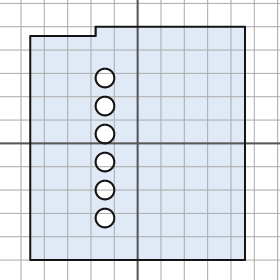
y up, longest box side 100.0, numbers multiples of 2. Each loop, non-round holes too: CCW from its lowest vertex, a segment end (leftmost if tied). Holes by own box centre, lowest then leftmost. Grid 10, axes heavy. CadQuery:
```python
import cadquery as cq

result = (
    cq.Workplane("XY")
    .moveTo(-46.0, -50.0)
    .lineTo(46.0, -50.0)
    .lineTo(46.0, 50.0)
    .lineTo(-18.0, 50.0)
    .lineTo(-18.0, 46.0)
    .lineTo(-46.0, 46.0)
    .close()
    .moveTo(-14.0, -32.0)
    .circle(4.0)
    .moveTo(-14.0, -20.0)
    .circle(4.0)
    .moveTo(-14.0, -8.0)
    .circle(4.0)
    .moveTo(-14.0, 4.0)
    .circle(4.0)
    .moveTo(-14.0, 16.0)
    .circle(4.0)
    .moveTo(-14.0, 28.0)
    .circle(4.0)
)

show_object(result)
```